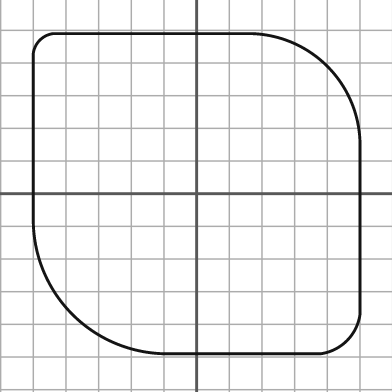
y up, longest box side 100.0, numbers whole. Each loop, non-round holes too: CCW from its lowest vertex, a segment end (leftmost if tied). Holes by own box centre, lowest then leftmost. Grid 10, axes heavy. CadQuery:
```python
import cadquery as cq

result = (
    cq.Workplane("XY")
    .moveTo(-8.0, -49.0)
    .lineTo(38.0, -49.0)
    .threePointArc((46.0, -45.0), (50.0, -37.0))
    .lineTo(50.0, 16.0)
    .threePointArc((40.0, 39.0), (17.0, 49.0))
    .lineTo(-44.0, 49.0)
    .threePointArc((-48.0, 47.0), (-50.0, 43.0))
    .lineTo(-50.0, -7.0)
    .threePointArc((-38.0, -37.0), (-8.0, -49.0))
    .close()
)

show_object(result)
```